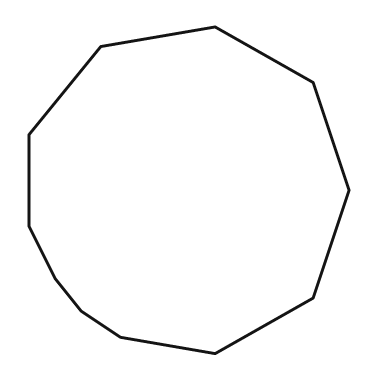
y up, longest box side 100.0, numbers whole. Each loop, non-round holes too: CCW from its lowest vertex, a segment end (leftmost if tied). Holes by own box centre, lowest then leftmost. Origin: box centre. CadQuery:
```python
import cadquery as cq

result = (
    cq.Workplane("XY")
    .moveTo(8.0, -50.0)
    .lineTo(38.0, -33.0)
    .lineTo(49.0, 0.0)
    .lineTo(38.0, 33.0)
    .lineTo(8.0, 50.0)
    .lineTo(-27.0, 44.0)
    .lineTo(-49.0, 17.0)
    .lineTo(-49.0, -11.0)
    .lineTo(-41.0, -27.0)
    .lineTo(-33.0, -37.0)
    .lineTo(-21.0, -45.0)
    .close()
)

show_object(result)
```